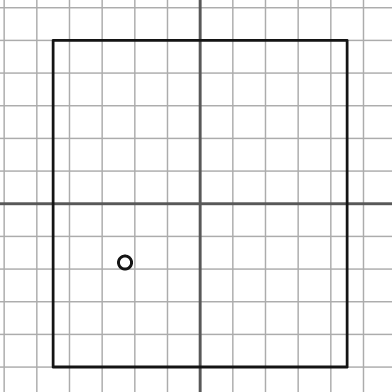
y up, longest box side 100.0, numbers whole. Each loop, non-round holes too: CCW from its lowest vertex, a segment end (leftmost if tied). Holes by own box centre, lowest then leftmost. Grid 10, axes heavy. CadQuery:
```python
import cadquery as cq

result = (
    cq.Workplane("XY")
    .moveTo(-45.0, -50.0)
    .lineTo(45.0, -50.0)
    .lineTo(45.0, 50.0)
    .lineTo(-45.0, 50.0)
    .close()
    .moveTo(-23.0, -18.0)
    .circle(2.0)
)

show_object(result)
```